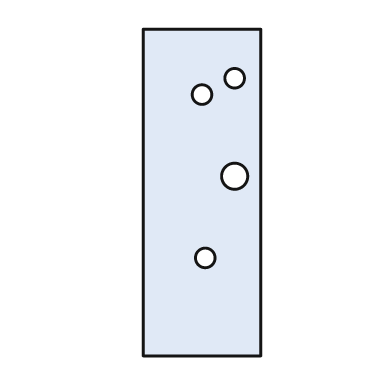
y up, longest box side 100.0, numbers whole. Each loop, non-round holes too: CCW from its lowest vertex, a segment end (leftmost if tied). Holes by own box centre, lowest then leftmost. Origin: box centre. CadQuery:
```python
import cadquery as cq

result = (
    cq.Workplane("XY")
    .moveTo(-18.0, -50.0)
    .lineTo(18.0, -50.0)
    .lineTo(18.0, 50.0)
    .lineTo(-18.0, 50.0)
    .close()
    .moveTo(1.0, -20.0)
    .circle(3.0)
    .moveTo(10.0, 5.0)
    .circle(4.0)
    .moveTo(0.0, 30.0)
    .circle(3.0)
    .moveTo(10.0, 35.0)
    .circle(3.0)
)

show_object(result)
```